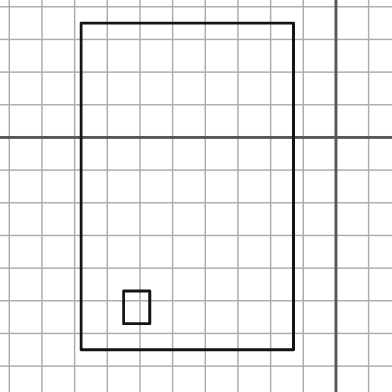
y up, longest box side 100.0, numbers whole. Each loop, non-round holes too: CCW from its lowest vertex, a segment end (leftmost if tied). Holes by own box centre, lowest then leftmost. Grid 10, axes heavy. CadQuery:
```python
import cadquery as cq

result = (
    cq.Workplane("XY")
    .moveTo(-78.0, -65.0)
    .lineTo(-13.0, -65.0)
    .lineTo(-13.0, 35.0)
    .lineTo(-78.0, 35.0)
    .close()
    .moveTo(-65.0, -57.0)
    .lineTo(-57.0, -57.0)
    .lineTo(-57.0, -47.0)
    .lineTo(-65.0, -47.0)
    .close()
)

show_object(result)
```